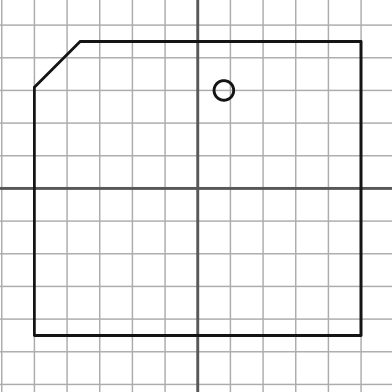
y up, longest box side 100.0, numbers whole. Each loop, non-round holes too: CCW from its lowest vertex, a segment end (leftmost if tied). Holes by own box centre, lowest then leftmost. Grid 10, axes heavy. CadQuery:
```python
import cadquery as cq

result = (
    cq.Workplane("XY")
    .moveTo(-50.0, -45.0)
    .lineTo(50.0, -45.0)
    .lineTo(50.0, 45.0)
    .lineTo(-36.0, 45.0)
    .lineTo(-50.0, 31.0)
    .close()
    .moveTo(8.0, 30.0)
    .circle(3.0)
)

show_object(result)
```